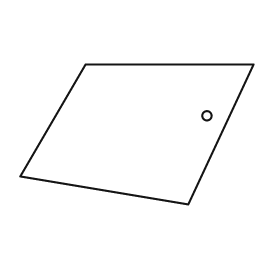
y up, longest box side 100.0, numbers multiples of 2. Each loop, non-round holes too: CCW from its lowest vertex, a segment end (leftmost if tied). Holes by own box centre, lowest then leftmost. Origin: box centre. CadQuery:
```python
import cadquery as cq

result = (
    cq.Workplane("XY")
    .moveTo(22.0, -30.0)
    .lineTo(50.0, 30.0)
    .lineTo(-22.0, 30.0)
    .lineTo(-50.0, -18.0)
    .close()
    .moveTo(30.0, 8.0)
    .circle(2.0)
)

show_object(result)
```